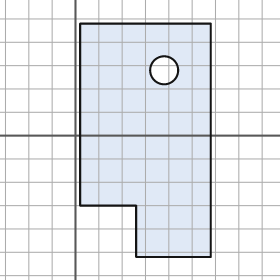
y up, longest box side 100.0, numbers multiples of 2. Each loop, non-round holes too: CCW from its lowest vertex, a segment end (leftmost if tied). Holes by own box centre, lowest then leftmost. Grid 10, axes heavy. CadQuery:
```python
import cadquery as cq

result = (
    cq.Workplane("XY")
    .moveTo(26.0, -52.0)
    .lineTo(58.0, -52.0)
    .lineTo(58.0, 48.0)
    .lineTo(2.0, 48.0)
    .lineTo(2.0, -30.0)
    .lineTo(26.0, -30.0)
    .close()
    .moveTo(38.0, 28.0)
    .circle(6.0)
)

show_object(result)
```